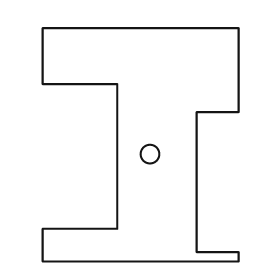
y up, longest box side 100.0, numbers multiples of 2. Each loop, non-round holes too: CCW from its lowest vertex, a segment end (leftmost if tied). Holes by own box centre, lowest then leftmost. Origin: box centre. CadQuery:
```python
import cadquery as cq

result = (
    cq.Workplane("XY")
    .moveTo(-42.0, -50.0)
    .lineTo(42.0, -50.0)
    .lineTo(42.0, -46.0)
    .lineTo(24.0, -46.0)
    .lineTo(24.0, 14.0)
    .lineTo(42.0, 14.0)
    .lineTo(42.0, 50.0)
    .lineTo(-42.0, 50.0)
    .lineTo(-42.0, 26.0)
    .lineTo(-10.0, 26.0)
    .lineTo(-10.0, -36.0)
    .lineTo(-42.0, -36.0)
    .close()
    .moveTo(4.0, -4.0)
    .circle(4.0)
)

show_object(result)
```